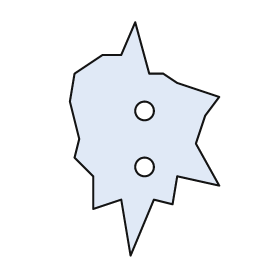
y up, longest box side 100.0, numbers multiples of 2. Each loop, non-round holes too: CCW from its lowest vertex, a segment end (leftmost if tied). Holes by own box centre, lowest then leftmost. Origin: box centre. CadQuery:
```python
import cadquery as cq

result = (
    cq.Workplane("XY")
    .moveTo(-6.0, -50.0)
    .lineTo(4.0, -26.0)
    .lineTo(12.0, -28.0)
    .lineTo(14.0, -16.0)
    .lineTo(32.0, -20.0)
    .lineTo(22.0, -2.0)
    .lineTo(26.0, 10.0)
    .lineTo(32.0, 18.0)
    .lineTo(14.0, 24.0)
    .lineTo(8.0, 28.0)
    .lineTo(2.0, 28.0)
    .lineTo(-4.0, 50.0)
    .lineTo(-10.0, 36.0)
    .lineTo(-18.0, 36.0)
    .lineTo(-30.0, 28.0)
    .lineTo(-32.0, 16.0)
    .lineTo(-28.0, 0.0)
    .lineTo(-30.0, -8.0)
    .lineTo(-22.0, -16.0)
    .lineTo(-22.0, -30.0)
    .lineTo(-10.0, -26.0)
    .close()
    .moveTo(0.0, -12.0)
    .circle(4.0)
    .moveTo(0.0, 12.0)
    .circle(4.0)
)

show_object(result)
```